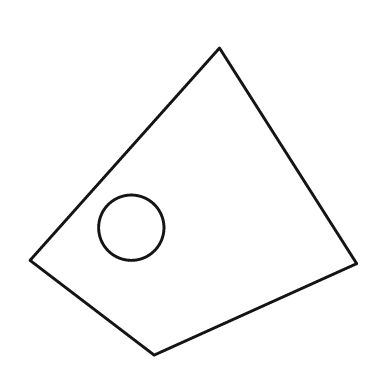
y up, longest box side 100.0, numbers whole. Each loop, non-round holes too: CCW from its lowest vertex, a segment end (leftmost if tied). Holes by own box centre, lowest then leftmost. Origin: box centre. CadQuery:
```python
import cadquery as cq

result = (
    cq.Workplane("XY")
    .moveTo(-12.0, -47.0)
    .lineTo(50.0, -19.0)
    .lineTo(8.0, 47.0)
    .lineTo(-50.0, -18.0)
    .close()
    .moveTo(-19.0, -8.0)
    .circle(10.0)
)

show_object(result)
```